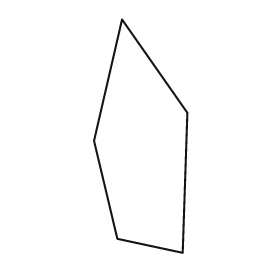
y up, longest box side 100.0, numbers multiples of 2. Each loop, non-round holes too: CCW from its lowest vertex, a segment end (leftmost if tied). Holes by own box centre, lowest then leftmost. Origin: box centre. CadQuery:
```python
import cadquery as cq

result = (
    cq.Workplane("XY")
    .moveTo(18.0, -50.0)
    .lineTo(20.0, 10.0)
    .lineTo(-8.0, 50.0)
    .lineTo(-20.0, -2.0)
    .lineTo(-10.0, -44.0)
    .close()
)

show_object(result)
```